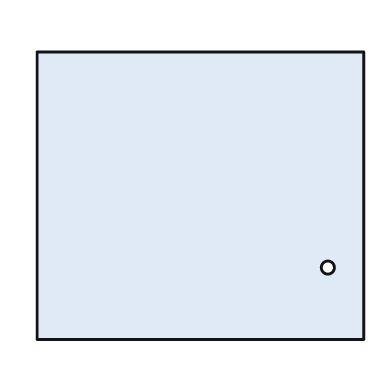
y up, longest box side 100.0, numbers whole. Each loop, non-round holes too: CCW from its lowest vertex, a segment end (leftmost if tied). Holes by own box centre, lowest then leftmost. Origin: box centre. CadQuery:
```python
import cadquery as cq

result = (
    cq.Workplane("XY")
    .moveTo(-50.0, -44.0)
    .lineTo(50.0, -44.0)
    .lineTo(50.0, 44.0)
    .lineTo(-50.0, 44.0)
    .close()
    .moveTo(39.0, -22.0)
    .circle(2.0)
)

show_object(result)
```